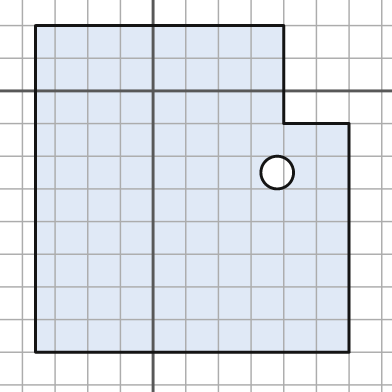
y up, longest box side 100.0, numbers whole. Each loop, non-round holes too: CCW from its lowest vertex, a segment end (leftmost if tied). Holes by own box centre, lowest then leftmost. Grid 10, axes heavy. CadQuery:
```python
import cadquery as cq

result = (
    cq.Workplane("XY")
    .moveTo(-36.0, -80.0)
    .lineTo(60.0, -80.0)
    .lineTo(60.0, -10.0)
    .lineTo(40.0, -10.0)
    .lineTo(40.0, 20.0)
    .lineTo(-36.0, 20.0)
    .close()
    .moveTo(38.0, -25.0)
    .circle(5.0)
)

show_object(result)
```